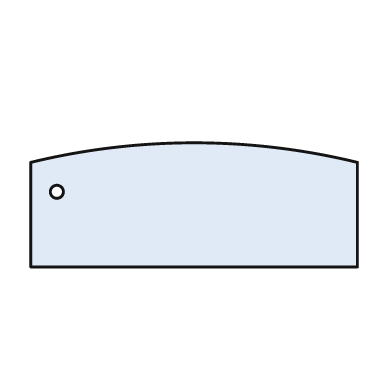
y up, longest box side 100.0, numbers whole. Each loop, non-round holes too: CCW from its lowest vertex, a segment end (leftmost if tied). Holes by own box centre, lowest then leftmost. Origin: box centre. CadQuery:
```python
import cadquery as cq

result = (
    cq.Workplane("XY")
    .moveTo(-50.0, -19.0)
    .lineTo(50.0, -19.0)
    .lineTo(50.0, 13.0)
    .threePointArc((0.0, 19.0), (-50.0, 13.0))
    .close()
    .moveTo(-42.0, 4.0)
    .circle(2.0)
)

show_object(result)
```